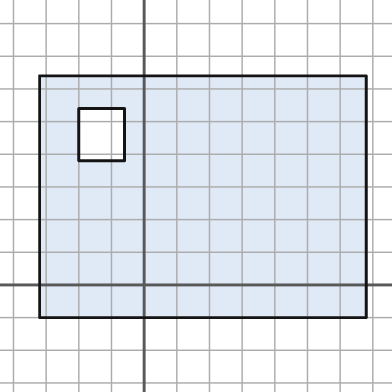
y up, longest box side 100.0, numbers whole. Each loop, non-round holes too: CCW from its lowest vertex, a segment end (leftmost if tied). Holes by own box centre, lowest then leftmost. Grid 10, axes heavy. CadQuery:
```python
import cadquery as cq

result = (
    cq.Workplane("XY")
    .moveTo(-32.0, -10.0)
    .lineTo(68.0, -10.0)
    .lineTo(68.0, 64.0)
    .lineTo(-32.0, 64.0)
    .close()
    .moveTo(-20.0, 38.0)
    .lineTo(-6.0, 38.0)
    .lineTo(-6.0, 54.0)
    .lineTo(-20.0, 54.0)
    .close()
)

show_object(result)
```